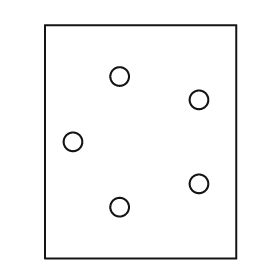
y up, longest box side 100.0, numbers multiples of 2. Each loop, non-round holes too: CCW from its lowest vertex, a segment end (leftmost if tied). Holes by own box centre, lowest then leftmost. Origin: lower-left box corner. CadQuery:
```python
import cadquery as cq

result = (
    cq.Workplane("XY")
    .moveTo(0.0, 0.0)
    .lineTo(82.0, 0.0)
    .lineTo(82.0, 100.0)
    .lineTo(0.0, 100.0)
    .close()
    .moveTo(32.0, 22.0)
    .circle(4.0)
    .moveTo(66.0, 32.0)
    .circle(4.0)
    .moveTo(12.0, 50.0)
    .circle(4.0)
    .moveTo(66.0, 68.0)
    .circle(4.0)
    .moveTo(32.0, 78.0)
    .circle(4.0)
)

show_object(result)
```